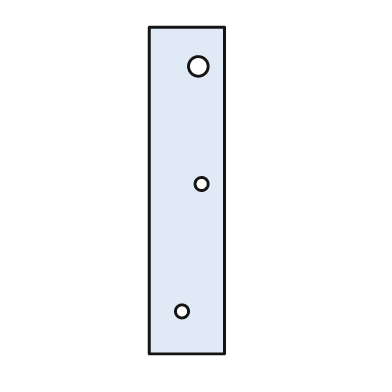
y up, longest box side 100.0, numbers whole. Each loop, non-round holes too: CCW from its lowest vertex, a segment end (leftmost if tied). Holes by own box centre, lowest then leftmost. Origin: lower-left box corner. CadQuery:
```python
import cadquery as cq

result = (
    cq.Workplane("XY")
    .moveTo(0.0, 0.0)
    .lineTo(23.0, 0.0)
    .lineTo(23.0, 100.0)
    .lineTo(0.0, 100.0)
    .close()
    .moveTo(10.0, 13.0)
    .circle(2.0)
    .moveTo(16.0, 52.0)
    .circle(2.0)
    .moveTo(15.0, 88.0)
    .circle(3.0)
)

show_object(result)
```